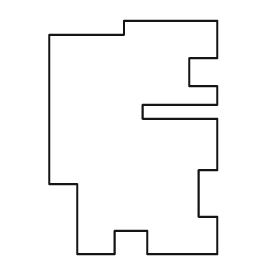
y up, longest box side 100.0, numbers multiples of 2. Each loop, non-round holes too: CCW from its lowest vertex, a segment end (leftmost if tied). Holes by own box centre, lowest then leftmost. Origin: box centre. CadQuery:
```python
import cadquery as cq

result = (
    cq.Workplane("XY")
    .moveTo(-24.0, -50.0)
    .lineTo(-8.0, -50.0)
    .lineTo(-8.0, -40.0)
    .lineTo(6.0, -40.0)
    .lineTo(6.0, -50.0)
    .lineTo(36.0, -50.0)
    .lineTo(36.0, -34.0)
    .lineTo(28.0, -34.0)
    .lineTo(28.0, -14.0)
    .lineTo(36.0, -14.0)
    .lineTo(36.0, 8.0)
    .lineTo(4.0, 8.0)
    .lineTo(4.0, 14.0)
    .lineTo(36.0, 14.0)
    .lineTo(36.0, 22.0)
    .lineTo(24.0, 22.0)
    .lineTo(24.0, 34.0)
    .lineTo(36.0, 34.0)
    .lineTo(36.0, 50.0)
    .lineTo(-4.0, 50.0)
    .lineTo(-4.0, 44.0)
    .lineTo(-36.0, 44.0)
    .lineTo(-36.0, -20.0)
    .lineTo(-24.0, -20.0)
    .close()
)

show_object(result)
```